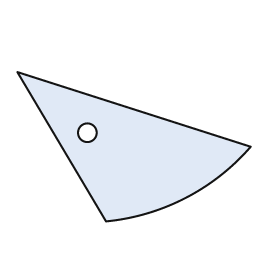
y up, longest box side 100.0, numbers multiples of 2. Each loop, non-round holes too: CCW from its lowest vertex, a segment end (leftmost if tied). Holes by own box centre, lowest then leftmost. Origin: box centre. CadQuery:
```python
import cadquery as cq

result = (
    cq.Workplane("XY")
    .moveTo(-12.0, -32.0)
    .threePointArc((22.0, -22.0), (50.0, 0.0))
    .lineTo(-50.0, 32.0)
    .close()
    .moveTo(-20.0, 6.0)
    .circle(4.0)
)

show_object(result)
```